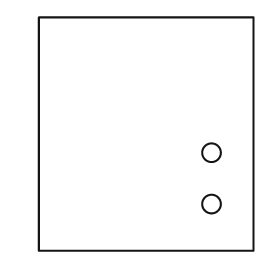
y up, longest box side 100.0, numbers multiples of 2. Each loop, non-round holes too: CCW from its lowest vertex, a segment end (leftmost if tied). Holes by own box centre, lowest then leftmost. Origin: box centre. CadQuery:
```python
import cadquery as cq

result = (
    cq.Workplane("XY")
    .moveTo(-46.0, -50.0)
    .lineTo(46.0, -50.0)
    .lineTo(46.0, 50.0)
    .lineTo(-46.0, 50.0)
    .close()
    .moveTo(28.0, -30.0)
    .circle(4.0)
    .moveTo(28.0, -8.0)
    .circle(4.0)
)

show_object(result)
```